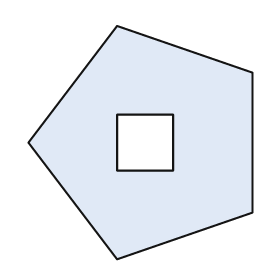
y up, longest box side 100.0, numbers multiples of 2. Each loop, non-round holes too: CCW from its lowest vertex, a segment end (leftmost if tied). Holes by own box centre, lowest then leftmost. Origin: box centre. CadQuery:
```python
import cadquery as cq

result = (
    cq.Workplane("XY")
    .moveTo(-10.0, -50.0)
    .lineTo(48.0, -30.0)
    .lineTo(48.0, 30.0)
    .lineTo(-10.0, 50.0)
    .lineTo(-48.0, 0.0)
    .close()
    .moveTo(-10.0, -12.0)
    .lineTo(14.0, -12.0)
    .lineTo(14.0, 12.0)
    .lineTo(-10.0, 12.0)
    .close()
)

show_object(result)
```